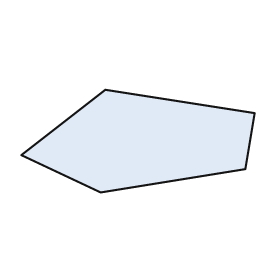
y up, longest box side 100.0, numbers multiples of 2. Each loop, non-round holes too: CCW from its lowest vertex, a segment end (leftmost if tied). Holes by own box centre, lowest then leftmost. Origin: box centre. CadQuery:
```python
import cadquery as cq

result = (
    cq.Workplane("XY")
    .moveTo(-16.0, -22.0)
    .lineTo(46.0, -12.0)
    .lineTo(50.0, 12.0)
    .lineTo(-14.0, 22.0)
    .lineTo(-50.0, -6.0)
    .close()
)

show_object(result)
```